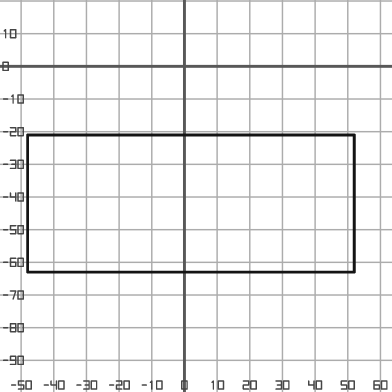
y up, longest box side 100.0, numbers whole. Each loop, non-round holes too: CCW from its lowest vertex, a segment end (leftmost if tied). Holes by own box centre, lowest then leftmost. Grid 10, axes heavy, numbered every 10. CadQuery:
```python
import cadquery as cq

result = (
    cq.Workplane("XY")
    .moveTo(-48.0, -63.0)
    .lineTo(52.0, -63.0)
    .lineTo(52.0, -21.0)
    .lineTo(-48.0, -21.0)
    .close()
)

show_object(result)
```